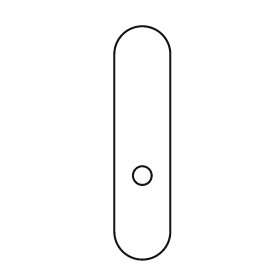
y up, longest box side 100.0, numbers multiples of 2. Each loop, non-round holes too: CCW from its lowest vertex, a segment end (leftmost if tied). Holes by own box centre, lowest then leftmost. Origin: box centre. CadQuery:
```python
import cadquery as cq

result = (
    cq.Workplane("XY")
    .moveTo(-12.0, -38.0)
    .threePointArc((0.0, -50.0), (12.0, -38.0))
    .lineTo(12.0, 38.0)
    .threePointArc((0.0, 50.0), (-12.0, 38.0))
    .close()
    .moveTo(0.0, -14.0)
    .circle(4.0)
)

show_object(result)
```